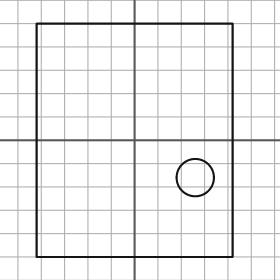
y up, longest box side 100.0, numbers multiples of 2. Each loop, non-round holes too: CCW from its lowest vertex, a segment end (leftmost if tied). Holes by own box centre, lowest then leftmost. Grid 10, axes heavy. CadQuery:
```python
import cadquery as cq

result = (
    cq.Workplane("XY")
    .moveTo(-42.0, -50.0)
    .lineTo(42.0, -50.0)
    .lineTo(42.0, 50.0)
    .lineTo(-42.0, 50.0)
    .close()
    .moveTo(26.0, -16.0)
    .circle(8.0)
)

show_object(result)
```